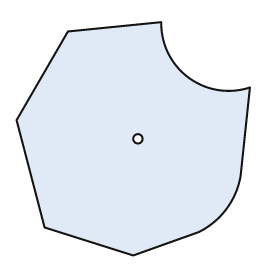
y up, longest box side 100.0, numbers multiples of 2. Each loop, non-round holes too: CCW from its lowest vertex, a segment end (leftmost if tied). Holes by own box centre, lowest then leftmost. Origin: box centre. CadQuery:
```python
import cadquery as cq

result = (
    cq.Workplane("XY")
    .moveTo(0.0, -50.0)
    .lineTo(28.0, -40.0)
    .threePointArc((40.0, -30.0), (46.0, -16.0))
    .lineTo(50.0, 22.0)
    .threePointArc((24.0, 26.0), (12.0, 50.0))
    .lineTo(-28.0, 46.0)
    .lineTo(-50.0, 8.0)
    .lineTo(-38.0, -38.0)
    .close()
    .moveTo(2.0, 0.0)
    .circle(2.0)
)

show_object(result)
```